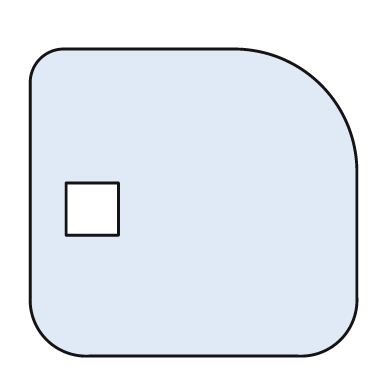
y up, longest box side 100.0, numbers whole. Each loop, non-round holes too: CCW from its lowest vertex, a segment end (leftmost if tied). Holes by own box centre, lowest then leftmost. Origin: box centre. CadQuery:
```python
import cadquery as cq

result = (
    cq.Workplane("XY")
    .moveTo(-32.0, -47.0)
    .lineTo(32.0, -47.0)
    .threePointArc((45.0, -42.0), (50.0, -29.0))
    .lineTo(50.0, 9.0)
    .threePointArc((39.0, 36.0), (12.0, 47.0))
    .lineTo(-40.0, 47.0)
    .threePointArc((-47.0, 44.0), (-50.0, 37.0))
    .lineTo(-50.0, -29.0)
    .threePointArc((-45.0, -42.0), (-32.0, -47.0))
    .close()
    .moveTo(-39.0, -10.0)
    .lineTo(-23.0, -10.0)
    .lineTo(-23.0, 6.0)
    .lineTo(-39.0, 6.0)
    .close()
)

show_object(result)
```